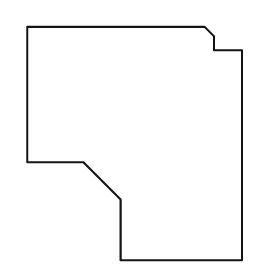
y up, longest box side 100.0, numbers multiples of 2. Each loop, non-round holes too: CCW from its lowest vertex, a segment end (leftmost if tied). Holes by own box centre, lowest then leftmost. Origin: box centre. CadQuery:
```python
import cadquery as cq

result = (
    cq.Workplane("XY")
    .moveTo(-6.0, -50.0)
    .lineTo(46.0, -50.0)
    .lineTo(46.0, 40.0)
    .lineTo(34.0, 40.0)
    .lineTo(34.0, 46.0)
    .lineTo(30.0, 50.0)
    .lineTo(-46.0, 50.0)
    .lineTo(-46.0, -8.0)
    .lineTo(-22.0, -8.0)
    .lineTo(-6.0, -24.0)
    .close()
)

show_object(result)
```